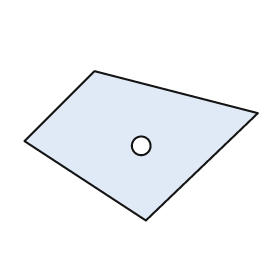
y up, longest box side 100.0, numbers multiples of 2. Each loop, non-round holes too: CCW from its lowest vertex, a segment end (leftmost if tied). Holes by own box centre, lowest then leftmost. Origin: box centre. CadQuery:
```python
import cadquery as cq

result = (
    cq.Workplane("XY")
    .moveTo(2.0, -32.0)
    .lineTo(50.0, 14.0)
    .lineTo(-20.0, 32.0)
    .lineTo(-50.0, 2.0)
    .close()
    .moveTo(0.0, 0.0)
    .circle(4.0)
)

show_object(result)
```